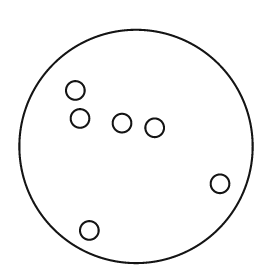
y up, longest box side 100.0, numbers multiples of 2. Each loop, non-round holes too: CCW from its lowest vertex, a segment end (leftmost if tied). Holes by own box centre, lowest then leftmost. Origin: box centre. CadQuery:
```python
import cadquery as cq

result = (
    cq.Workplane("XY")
    .moveTo(0.0, 0.0)
    .circle(50.0)
    .moveTo(-20.0, -36.0)
    .circle(4.0)
    .moveTo(36.0, -16.0)
    .circle(4.0)
    .moveTo(8.0, 8.0)
    .circle(4.0)
    .moveTo(-6.0, 10.0)
    .circle(4.0)
    .moveTo(-24.0, 12.0)
    .circle(4.0)
    .moveTo(-26.0, 24.0)
    .circle(4.0)
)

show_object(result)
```